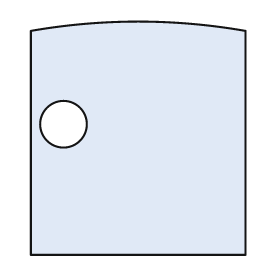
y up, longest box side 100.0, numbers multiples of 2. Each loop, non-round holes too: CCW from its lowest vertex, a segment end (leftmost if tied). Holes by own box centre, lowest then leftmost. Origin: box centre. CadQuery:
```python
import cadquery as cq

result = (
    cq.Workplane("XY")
    .moveTo(-46.0, -50.0)
    .lineTo(46.0, -50.0)
    .lineTo(46.0, 46.0)
    .threePointArc((0.0, 50.0), (-46.0, 46.0))
    .close()
    .moveTo(-32.0, 6.0)
    .circle(10.0)
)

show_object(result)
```